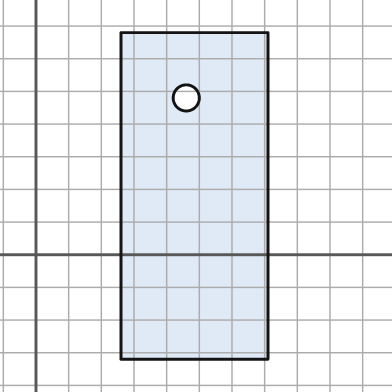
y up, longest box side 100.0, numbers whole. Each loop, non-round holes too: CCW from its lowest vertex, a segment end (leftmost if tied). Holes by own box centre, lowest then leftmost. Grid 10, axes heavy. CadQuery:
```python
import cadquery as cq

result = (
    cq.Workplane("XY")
    .moveTo(26.0, -32.0)
    .lineTo(71.0, -32.0)
    .lineTo(71.0, 68.0)
    .lineTo(26.0, 68.0)
    .close()
    .moveTo(46.0, 48.0)
    .circle(4.0)
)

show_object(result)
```